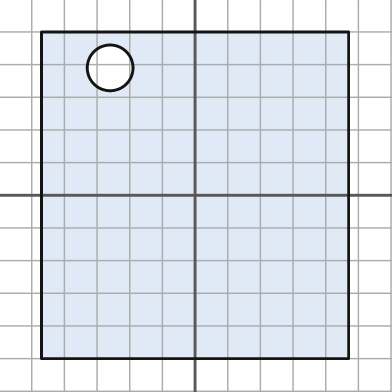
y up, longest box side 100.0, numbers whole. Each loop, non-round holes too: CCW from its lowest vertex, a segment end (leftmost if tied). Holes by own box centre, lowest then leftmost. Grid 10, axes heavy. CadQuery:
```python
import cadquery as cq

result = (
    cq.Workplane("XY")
    .moveTo(-47.0, -50.0)
    .lineTo(47.0, -50.0)
    .lineTo(47.0, 50.0)
    .lineTo(-47.0, 50.0)
    .close()
    .moveTo(-26.0, 39.0)
    .circle(7.0)
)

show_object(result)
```